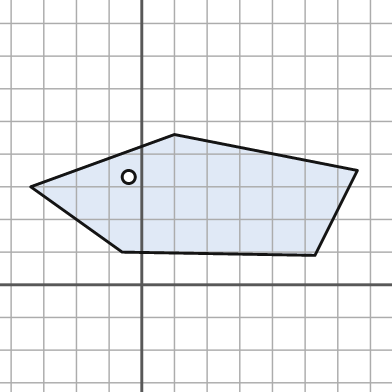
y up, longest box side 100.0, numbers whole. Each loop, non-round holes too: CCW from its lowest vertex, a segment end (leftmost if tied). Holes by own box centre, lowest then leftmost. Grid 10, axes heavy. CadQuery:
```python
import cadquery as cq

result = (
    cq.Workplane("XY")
    .moveTo(53.0, 9.0)
    .lineTo(66.0, 35.0)
    .lineTo(10.0, 46.0)
    .lineTo(-34.0, 30.0)
    .lineTo(-6.0, 10.0)
    .close()
    .moveTo(-4.0, 33.0)
    .circle(2.0)
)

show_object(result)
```